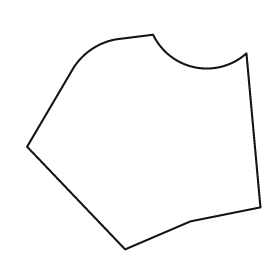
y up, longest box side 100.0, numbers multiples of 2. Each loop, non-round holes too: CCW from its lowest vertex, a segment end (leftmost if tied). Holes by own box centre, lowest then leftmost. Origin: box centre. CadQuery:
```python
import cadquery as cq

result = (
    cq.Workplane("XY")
    .moveTo(-8.0, -46.0)
    .lineTo(20.0, -34.0)
    .lineTo(50.0, -28.0)
    .lineTo(44.0, 38.0)
    .threePointArc((22.0, 32.0), (4.0, 46.0))
    .lineTo(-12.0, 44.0)
    .threePointArc((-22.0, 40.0), (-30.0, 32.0))
    .lineTo(-50.0, -2.0)
    .close()
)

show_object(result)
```